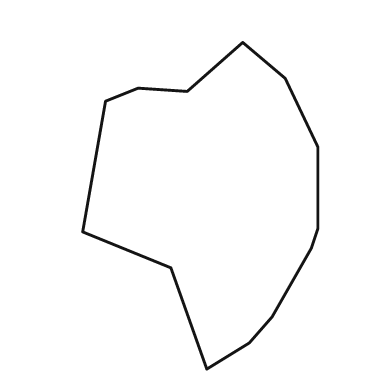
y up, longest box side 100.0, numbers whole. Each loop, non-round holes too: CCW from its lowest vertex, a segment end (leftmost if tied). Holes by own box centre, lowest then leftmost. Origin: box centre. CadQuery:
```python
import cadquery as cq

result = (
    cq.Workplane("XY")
    .moveTo(2.0, -50.0)
    .lineTo(15.0, -42.0)
    .lineTo(22.0, -34.0)
    .lineTo(34.0, -13.0)
    .lineTo(36.0, -7.0)
    .lineTo(36.0, 18.0)
    .lineTo(26.0, 39.0)
    .lineTo(13.0, 50.0)
    .lineTo(-4.0, 35.0)
    .lineTo(-19.0, 36.0)
    .lineTo(-29.0, 32.0)
    .lineTo(-36.0, -8.0)
    .lineTo(-9.0, -19.0)
    .close()
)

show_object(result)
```